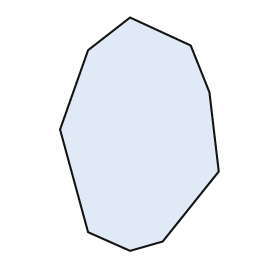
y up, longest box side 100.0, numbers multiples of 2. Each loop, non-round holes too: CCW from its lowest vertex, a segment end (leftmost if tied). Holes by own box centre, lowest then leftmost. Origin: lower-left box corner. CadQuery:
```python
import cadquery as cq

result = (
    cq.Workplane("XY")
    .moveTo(30.0, 0.0)
    .lineTo(44.0, 4.0)
    .lineTo(68.0, 34.0)
    .lineTo(64.0, 68.0)
    .lineTo(56.0, 88.0)
    .lineTo(30.0, 100.0)
    .lineTo(12.0, 86.0)
    .lineTo(0.0, 52.0)
    .lineTo(12.0, 8.0)
    .close()
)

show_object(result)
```